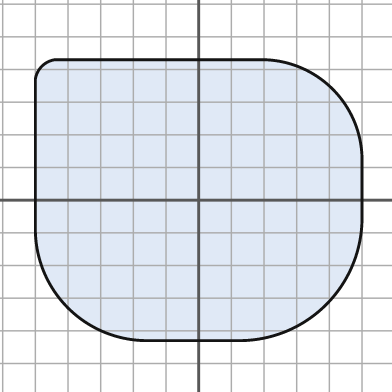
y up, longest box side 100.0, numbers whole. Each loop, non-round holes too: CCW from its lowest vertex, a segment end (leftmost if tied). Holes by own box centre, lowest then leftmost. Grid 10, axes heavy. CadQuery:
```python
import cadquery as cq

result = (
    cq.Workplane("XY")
    .moveTo(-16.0, -43.0)
    .lineTo(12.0, -43.0)
    .threePointArc((39.0, -32.0), (50.0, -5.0))
    .lineTo(50.0, 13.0)
    .threePointArc((41.0, 34.0), (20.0, 43.0))
    .lineTo(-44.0, 43.0)
    .threePointArc((-48.0, 41.0), (-50.0, 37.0))
    .lineTo(-50.0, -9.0)
    .threePointArc((-40.0, -33.0), (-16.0, -43.0))
    .close()
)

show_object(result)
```